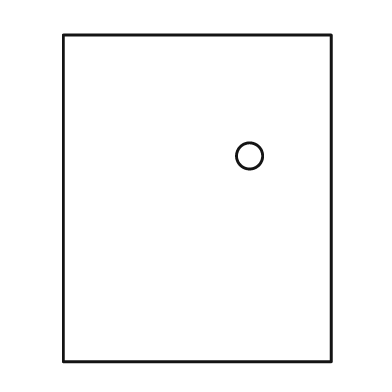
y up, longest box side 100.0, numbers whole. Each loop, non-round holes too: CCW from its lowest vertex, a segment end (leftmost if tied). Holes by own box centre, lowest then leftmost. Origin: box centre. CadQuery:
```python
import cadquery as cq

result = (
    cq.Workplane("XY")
    .moveTo(-41.0, -50.0)
    .lineTo(41.0, -50.0)
    .lineTo(41.0, 50.0)
    .lineTo(-41.0, 50.0)
    .close()
    .moveTo(16.0, 13.0)
    .circle(4.0)
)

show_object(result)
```